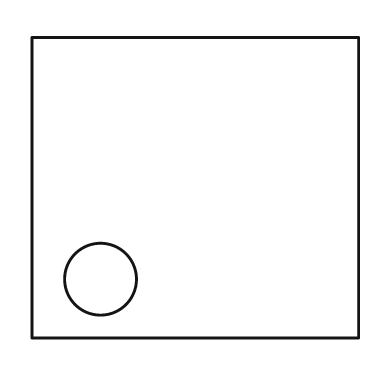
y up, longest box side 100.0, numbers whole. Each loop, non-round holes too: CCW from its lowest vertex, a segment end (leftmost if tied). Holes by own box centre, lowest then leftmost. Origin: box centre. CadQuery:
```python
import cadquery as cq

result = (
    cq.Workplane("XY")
    .moveTo(-50.0, -46.0)
    .lineTo(50.0, -46.0)
    .lineTo(50.0, 46.0)
    .lineTo(-50.0, 46.0)
    .close()
    .moveTo(-29.0, -28.0)
    .circle(11.0)
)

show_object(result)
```